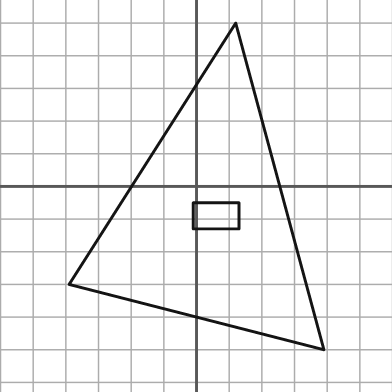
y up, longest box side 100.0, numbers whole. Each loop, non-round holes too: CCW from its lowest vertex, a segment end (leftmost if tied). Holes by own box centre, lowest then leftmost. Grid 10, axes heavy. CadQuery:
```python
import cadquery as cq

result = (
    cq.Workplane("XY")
    .moveTo(39.0, -50.0)
    .lineTo(12.0, 50.0)
    .lineTo(-39.0, -30.0)
    .close()
    .moveTo(-1.0, -13.0)
    .lineTo(13.0, -13.0)
    .lineTo(13.0, -5.0)
    .lineTo(-1.0, -5.0)
    .close()
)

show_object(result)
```